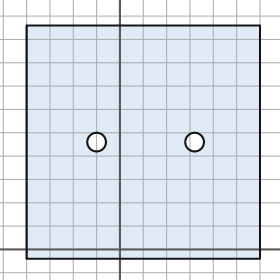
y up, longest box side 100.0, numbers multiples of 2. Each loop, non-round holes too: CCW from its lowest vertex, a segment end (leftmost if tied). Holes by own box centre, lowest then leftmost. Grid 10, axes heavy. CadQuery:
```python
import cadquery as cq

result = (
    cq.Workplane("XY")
    .moveTo(-40.0, -4.0)
    .lineTo(60.0, -4.0)
    .lineTo(60.0, 96.0)
    .lineTo(-40.0, 96.0)
    .close()
    .moveTo(-10.0, 46.0)
    .circle(4.0)
    .moveTo(32.0, 46.0)
    .circle(4.0)
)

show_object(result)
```